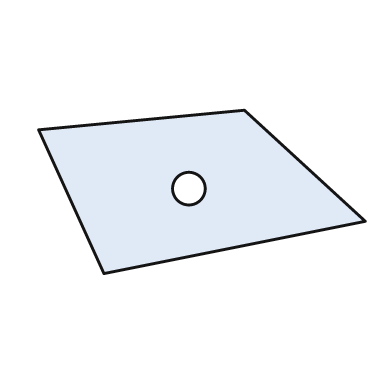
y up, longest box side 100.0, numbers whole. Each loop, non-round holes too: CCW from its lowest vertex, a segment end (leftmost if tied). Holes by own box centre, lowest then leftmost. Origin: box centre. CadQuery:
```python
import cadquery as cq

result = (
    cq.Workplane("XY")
    .moveTo(-30.0, -25.0)
    .lineTo(50.0, -9.0)
    .lineTo(13.0, 25.0)
    .lineTo(-50.0, 19.0)
    .close()
    .moveTo(-4.0, 1.0)
    .circle(5.0)
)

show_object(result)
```